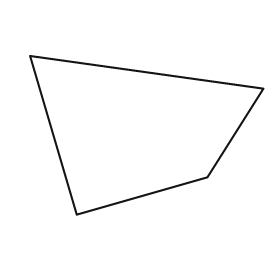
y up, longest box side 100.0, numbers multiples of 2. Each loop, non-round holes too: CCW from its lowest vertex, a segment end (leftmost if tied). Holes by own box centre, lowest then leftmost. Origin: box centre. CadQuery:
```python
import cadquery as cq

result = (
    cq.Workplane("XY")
    .moveTo(-30.0, -34.0)
    .lineTo(26.0, -18.0)
    .lineTo(50.0, 20.0)
    .lineTo(-50.0, 34.0)
    .close()
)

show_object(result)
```